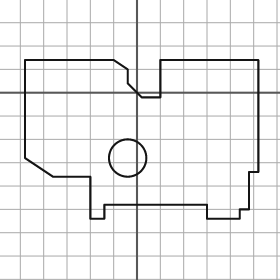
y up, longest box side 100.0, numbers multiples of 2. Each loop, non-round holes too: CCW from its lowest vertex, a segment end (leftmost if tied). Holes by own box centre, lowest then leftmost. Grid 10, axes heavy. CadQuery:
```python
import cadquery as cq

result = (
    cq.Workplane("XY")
    .moveTo(-20.0, -54.0)
    .lineTo(-14.0, -54.0)
    .lineTo(-14.0, -48.0)
    .lineTo(30.0, -48.0)
    .lineTo(30.0, -54.0)
    .lineTo(44.0, -54.0)
    .lineTo(44.0, -50.0)
    .lineTo(48.0, -50.0)
    .lineTo(48.0, -34.0)
    .lineTo(52.0, -34.0)
    .lineTo(52.0, 14.0)
    .lineTo(10.0, 14.0)
    .lineTo(10.0, -2.0)
    .lineTo(2.0, -2.0)
    .lineTo(-4.0, 4.0)
    .lineTo(-4.0, 10.0)
    .lineTo(-10.0, 14.0)
    .lineTo(-48.0, 14.0)
    .lineTo(-48.0, -28.0)
    .lineTo(-36.0, -36.0)
    .lineTo(-20.0, -36.0)
    .close()
    .moveTo(-4.0, -28.0)
    .circle(8.0)
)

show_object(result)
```